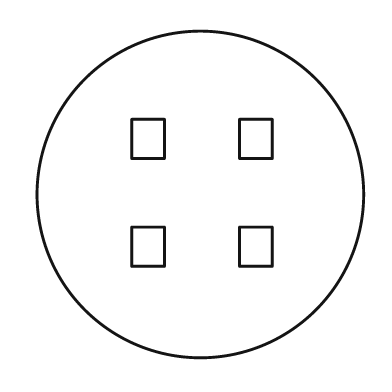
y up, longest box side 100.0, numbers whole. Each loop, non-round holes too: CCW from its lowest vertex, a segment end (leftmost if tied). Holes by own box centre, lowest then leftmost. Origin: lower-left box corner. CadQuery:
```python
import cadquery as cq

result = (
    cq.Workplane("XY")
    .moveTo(50.0, 50.0)
    .circle(50.0)
    .moveTo(29.0, 28.0)
    .lineTo(39.0, 28.0)
    .lineTo(39.0, 40.0)
    .lineTo(29.0, 40.0)
    .close()
    .moveTo(62.0, 28.0)
    .lineTo(72.0, 28.0)
    .lineTo(72.0, 40.0)
    .lineTo(62.0, 40.0)
    .close()
    .moveTo(29.0, 61.0)
    .lineTo(39.0, 61.0)
    .lineTo(39.0, 73.0)
    .lineTo(29.0, 73.0)
    .close()
    .moveTo(62.0, 61.0)
    .lineTo(72.0, 61.0)
    .lineTo(72.0, 73.0)
    .lineTo(62.0, 73.0)
    .close()
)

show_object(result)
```